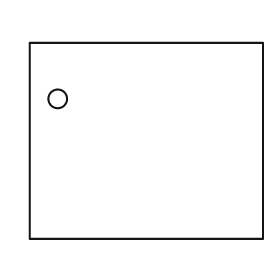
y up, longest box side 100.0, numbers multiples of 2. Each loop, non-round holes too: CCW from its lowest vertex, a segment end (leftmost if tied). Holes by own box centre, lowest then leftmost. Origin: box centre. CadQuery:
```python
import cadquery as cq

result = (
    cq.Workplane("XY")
    .moveTo(-50.0, -42.0)
    .lineTo(50.0, -42.0)
    .lineTo(50.0, 42.0)
    .lineTo(-50.0, 42.0)
    .close()
    .moveTo(-38.0, 18.0)
    .circle(4.0)
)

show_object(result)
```